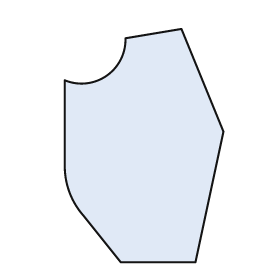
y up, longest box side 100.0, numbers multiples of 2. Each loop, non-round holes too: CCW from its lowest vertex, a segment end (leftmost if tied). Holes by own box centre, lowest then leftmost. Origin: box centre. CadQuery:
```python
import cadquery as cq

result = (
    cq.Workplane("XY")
    .moveTo(-10.0, -50.0)
    .lineTo(22.0, -50.0)
    .lineTo(34.0, 6.0)
    .lineTo(16.0, 50.0)
    .lineTo(-8.0, 46.0)
    .threePointArc((-16.0, 30.0), (-34.0, 28.0))
    .lineTo(-34.0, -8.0)
    .threePointArc((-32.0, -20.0), (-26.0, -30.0))
    .close()
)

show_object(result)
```